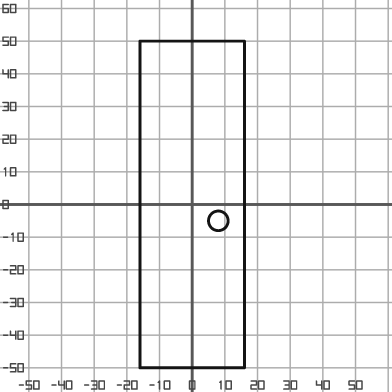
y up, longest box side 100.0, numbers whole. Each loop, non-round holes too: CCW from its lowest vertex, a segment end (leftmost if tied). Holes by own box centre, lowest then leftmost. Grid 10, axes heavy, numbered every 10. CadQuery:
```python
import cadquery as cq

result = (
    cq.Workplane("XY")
    .moveTo(-16.0, -50.0)
    .lineTo(16.0, -50.0)
    .lineTo(16.0, 50.0)
    .lineTo(-16.0, 50.0)
    .close()
    .moveTo(8.0, -5.0)
    .circle(3.0)
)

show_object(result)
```